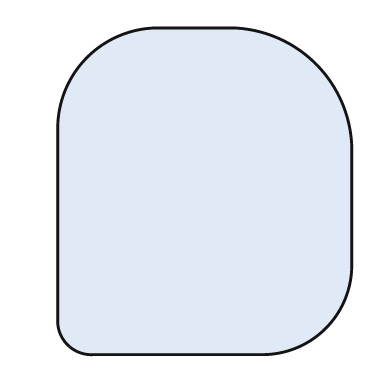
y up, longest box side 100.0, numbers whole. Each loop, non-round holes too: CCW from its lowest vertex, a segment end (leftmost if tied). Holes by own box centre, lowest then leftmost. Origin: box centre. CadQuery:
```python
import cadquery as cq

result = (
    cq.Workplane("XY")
    .moveTo(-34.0, -50.0)
    .lineTo(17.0, -50.0)
    .threePointArc((37.0, -42.0), (45.0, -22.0))
    .lineTo(45.0, 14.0)
    .threePointArc((34.0, 39.0), (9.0, 50.0))
    .lineTo(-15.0, 50.0)
    .threePointArc((-36.0, 41.0), (-45.0, 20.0))
    .lineTo(-45.0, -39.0)
    .threePointArc((-42.0, -47.0), (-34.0, -50.0))
    .close()
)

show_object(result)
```